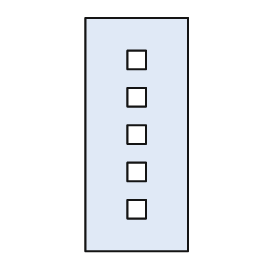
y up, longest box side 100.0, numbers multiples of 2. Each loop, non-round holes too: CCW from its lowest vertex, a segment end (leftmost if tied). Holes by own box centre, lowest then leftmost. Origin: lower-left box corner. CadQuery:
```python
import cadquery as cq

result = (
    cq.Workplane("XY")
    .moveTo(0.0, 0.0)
    .lineTo(44.0, 0.0)
    .lineTo(44.0, 100.0)
    .lineTo(0.0, 100.0)
    .close()
    .moveTo(18.0, 14.0)
    .lineTo(26.0, 14.0)
    .lineTo(26.0, 22.0)
    .lineTo(18.0, 22.0)
    .close()
    .moveTo(18.0, 30.0)
    .lineTo(26.0, 30.0)
    .lineTo(26.0, 38.0)
    .lineTo(18.0, 38.0)
    .close()
    .moveTo(18.0, 46.0)
    .lineTo(26.0, 46.0)
    .lineTo(26.0, 54.0)
    .lineTo(18.0, 54.0)
    .close()
    .moveTo(18.0, 62.0)
    .lineTo(26.0, 62.0)
    .lineTo(26.0, 70.0)
    .lineTo(18.0, 70.0)
    .close()
    .moveTo(18.0, 78.0)
    .lineTo(26.0, 78.0)
    .lineTo(26.0, 86.0)
    .lineTo(18.0, 86.0)
    .close()
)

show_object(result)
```